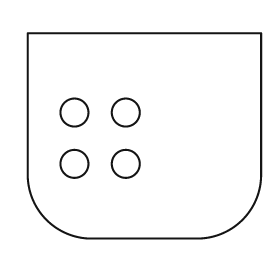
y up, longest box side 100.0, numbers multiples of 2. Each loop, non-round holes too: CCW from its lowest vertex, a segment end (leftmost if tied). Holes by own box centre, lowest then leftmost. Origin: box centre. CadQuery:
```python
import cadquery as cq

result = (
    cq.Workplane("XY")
    .moveTo(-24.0, -44.0)
    .lineTo(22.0, -44.0)
    .threePointArc((42.0, -36.0), (50.0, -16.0))
    .lineTo(50.0, 44.0)
    .lineTo(-50.0, 44.0)
    .lineTo(-50.0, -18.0)
    .threePointArc((-42.0, -36.0), (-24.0, -44.0))
    .close()
    .moveTo(-30.0, -12.0)
    .circle(6.0)
    .moveTo(-8.0, -12.0)
    .circle(6.0)
    .moveTo(-30.0, 10.0)
    .circle(6.0)
    .moveTo(-8.0, 10.0)
    .circle(6.0)
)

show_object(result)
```